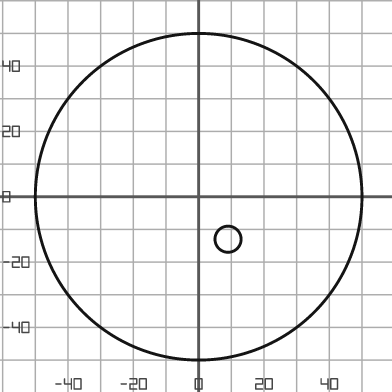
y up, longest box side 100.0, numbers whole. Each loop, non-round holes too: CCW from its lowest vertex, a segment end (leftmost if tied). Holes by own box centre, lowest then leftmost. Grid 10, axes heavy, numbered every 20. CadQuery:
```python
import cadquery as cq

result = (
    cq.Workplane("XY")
    .moveTo(0.0, 0.0)
    .circle(50.0)
    .moveTo(9.0, -13.0)
    .circle(4.0)
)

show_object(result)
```